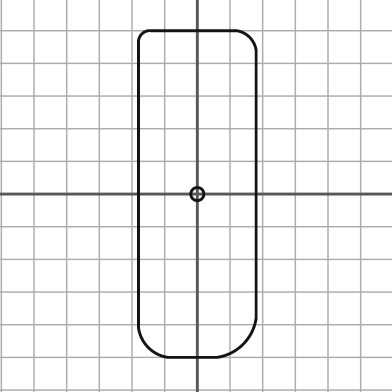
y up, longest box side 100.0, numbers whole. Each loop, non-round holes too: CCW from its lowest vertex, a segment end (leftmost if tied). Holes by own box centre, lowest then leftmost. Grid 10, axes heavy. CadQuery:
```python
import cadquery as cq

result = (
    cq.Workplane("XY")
    .moveTo(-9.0, -50.0)
    .lineTo(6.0, -50.0)
    .threePointArc((14.0, -46.0), (18.0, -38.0))
    .lineTo(18.0, 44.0)
    .threePointArc((16.0, 48.0), (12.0, 50.0))
    .lineTo(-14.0, 50.0)
    .threePointArc((-17.0, 49.0), (-18.0, 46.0))
    .lineTo(-18.0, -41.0)
    .threePointArc((-15.0, -47.0), (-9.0, -50.0))
    .close()
    .moveTo(0.0, 0.0)
    .circle(2.0)
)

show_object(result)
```